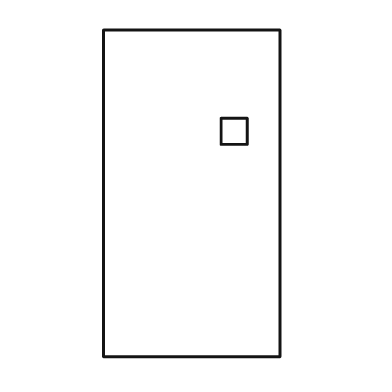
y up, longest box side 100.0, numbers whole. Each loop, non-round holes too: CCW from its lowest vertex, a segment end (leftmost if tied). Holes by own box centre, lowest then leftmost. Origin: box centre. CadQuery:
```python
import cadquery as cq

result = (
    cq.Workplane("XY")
    .moveTo(-27.0, -50.0)
    .lineTo(27.0, -50.0)
    .lineTo(27.0, 50.0)
    .lineTo(-27.0, 50.0)
    .close()
    .moveTo(9.0, 15.0)
    .lineTo(17.0, 15.0)
    .lineTo(17.0, 23.0)
    .lineTo(9.0, 23.0)
    .close()
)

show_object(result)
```